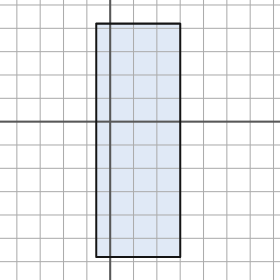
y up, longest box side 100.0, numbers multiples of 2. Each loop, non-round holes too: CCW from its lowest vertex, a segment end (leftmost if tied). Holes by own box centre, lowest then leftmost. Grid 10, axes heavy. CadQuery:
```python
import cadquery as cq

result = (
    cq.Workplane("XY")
    .moveTo(-6.0, -58.0)
    .lineTo(30.0, -58.0)
    .lineTo(30.0, 42.0)
    .lineTo(-6.0, 42.0)
    .close()
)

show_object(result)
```